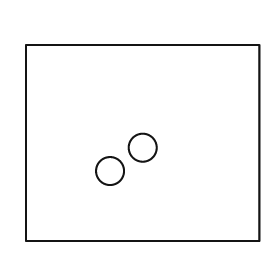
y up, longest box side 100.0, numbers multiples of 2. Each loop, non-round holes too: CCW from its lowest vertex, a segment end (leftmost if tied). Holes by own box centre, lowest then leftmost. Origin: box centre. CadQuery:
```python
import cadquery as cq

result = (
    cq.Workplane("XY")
    .moveTo(-50.0, -42.0)
    .lineTo(50.0, -42.0)
    .lineTo(50.0, 42.0)
    .lineTo(-50.0, 42.0)
    .close()
    .moveTo(-14.0, -12.0)
    .circle(6.0)
    .moveTo(0.0, -2.0)
    .circle(6.0)
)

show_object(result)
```